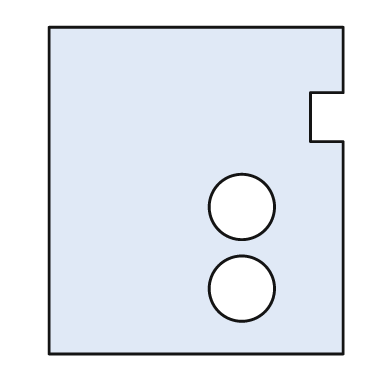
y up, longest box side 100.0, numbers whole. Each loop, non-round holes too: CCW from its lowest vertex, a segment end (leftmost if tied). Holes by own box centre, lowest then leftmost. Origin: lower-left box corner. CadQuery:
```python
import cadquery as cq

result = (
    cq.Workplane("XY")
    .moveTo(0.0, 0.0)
    .lineTo(90.0, 0.0)
    .lineTo(90.0, 65.0)
    .lineTo(80.0, 65.0)
    .lineTo(80.0, 80.0)
    .lineTo(90.0, 80.0)
    .lineTo(90.0, 100.0)
    .lineTo(0.0, 100.0)
    .close()
    .moveTo(59.0, 20.0)
    .circle(10.0)
    .moveTo(59.0, 45.0)
    .circle(10.0)
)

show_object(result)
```